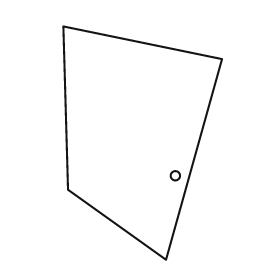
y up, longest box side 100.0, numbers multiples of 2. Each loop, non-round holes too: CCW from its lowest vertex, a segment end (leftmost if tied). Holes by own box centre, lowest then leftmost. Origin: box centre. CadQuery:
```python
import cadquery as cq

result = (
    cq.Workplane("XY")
    .moveTo(10.0, -50.0)
    .lineTo(34.0, 36.0)
    .lineTo(-34.0, 50.0)
    .lineTo(-32.0, -20.0)
    .close()
    .moveTo(14.0, -14.0)
    .circle(2.0)
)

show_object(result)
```